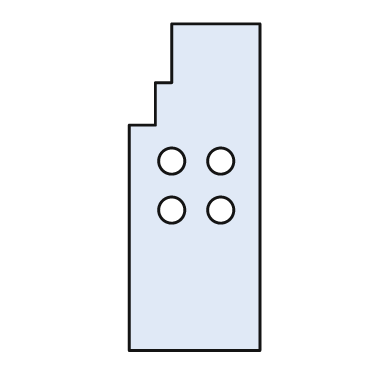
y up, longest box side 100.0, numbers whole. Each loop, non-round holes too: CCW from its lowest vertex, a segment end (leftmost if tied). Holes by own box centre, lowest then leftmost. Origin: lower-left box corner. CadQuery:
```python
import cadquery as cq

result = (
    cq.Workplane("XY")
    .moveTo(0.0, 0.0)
    .lineTo(40.0, 0.0)
    .lineTo(40.0, 100.0)
    .lineTo(13.0, 100.0)
    .lineTo(13.0, 82.0)
    .lineTo(8.0, 82.0)
    .lineTo(8.0, 69.0)
    .lineTo(0.0, 69.0)
    .close()
    .moveTo(13.0, 43.0)
    .circle(4.0)
    .moveTo(28.0, 43.0)
    .circle(4.0)
    .moveTo(13.0, 58.0)
    .circle(4.0)
    .moveTo(28.0, 58.0)
    .circle(4.0)
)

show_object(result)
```